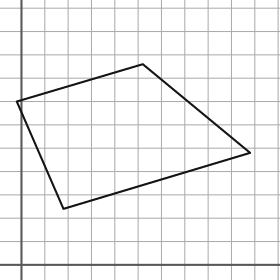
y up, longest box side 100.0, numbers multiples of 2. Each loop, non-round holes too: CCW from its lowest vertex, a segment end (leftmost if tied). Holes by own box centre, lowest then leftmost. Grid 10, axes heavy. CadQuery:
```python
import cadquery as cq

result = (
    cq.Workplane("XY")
    .moveTo(18.0, 24.0)
    .lineTo(98.0, 48.0)
    .lineTo(52.0, 86.0)
    .lineTo(-2.0, 70.0)
    .close()
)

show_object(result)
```